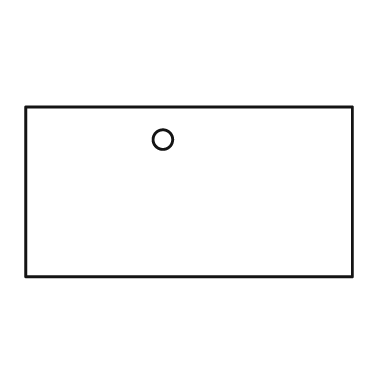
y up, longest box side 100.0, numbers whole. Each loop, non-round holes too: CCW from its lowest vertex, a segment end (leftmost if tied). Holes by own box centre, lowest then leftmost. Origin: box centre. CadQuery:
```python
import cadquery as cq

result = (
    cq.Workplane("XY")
    .moveTo(-50.0, -26.0)
    .lineTo(50.0, -26.0)
    .lineTo(50.0, 26.0)
    .lineTo(-50.0, 26.0)
    .close()
    .moveTo(-8.0, 16.0)
    .circle(3.0)
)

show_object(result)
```